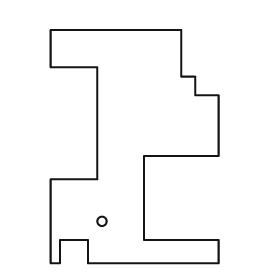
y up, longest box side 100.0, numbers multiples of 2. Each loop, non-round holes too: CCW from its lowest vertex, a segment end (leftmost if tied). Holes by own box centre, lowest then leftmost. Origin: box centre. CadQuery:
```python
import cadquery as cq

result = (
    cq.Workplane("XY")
    .moveTo(-36.0, -50.0)
    .lineTo(-32.0, -50.0)
    .lineTo(-32.0, -40.0)
    .lineTo(-20.0, -40.0)
    .lineTo(-20.0, -50.0)
    .lineTo(36.0, -50.0)
    .lineTo(36.0, -40.0)
    .lineTo(4.0, -40.0)
    .lineTo(4.0, -4.0)
    .lineTo(36.0, -4.0)
    .lineTo(36.0, 22.0)
    .lineTo(26.0, 22.0)
    .lineTo(26.0, 30.0)
    .lineTo(20.0, 30.0)
    .lineTo(20.0, 50.0)
    .lineTo(-36.0, 50.0)
    .lineTo(-36.0, 34.0)
    .lineTo(-16.0, 34.0)
    .lineTo(-16.0, -14.0)
    .lineTo(-36.0, -14.0)
    .close()
    .moveTo(-14.0, -32.0)
    .circle(2.0)
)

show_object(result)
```